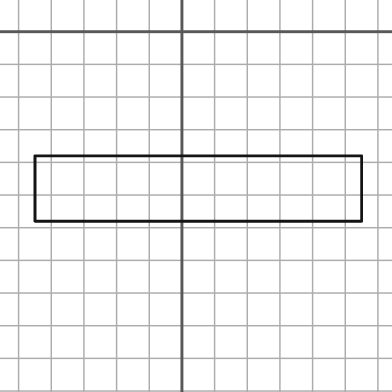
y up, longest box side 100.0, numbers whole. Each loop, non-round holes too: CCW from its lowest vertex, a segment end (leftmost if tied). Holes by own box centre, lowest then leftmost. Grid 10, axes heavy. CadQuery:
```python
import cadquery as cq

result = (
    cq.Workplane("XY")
    .moveTo(-45.0, -58.0)
    .lineTo(55.0, -58.0)
    .lineTo(55.0, -38.0)
    .lineTo(-45.0, -38.0)
    .close()
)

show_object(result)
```